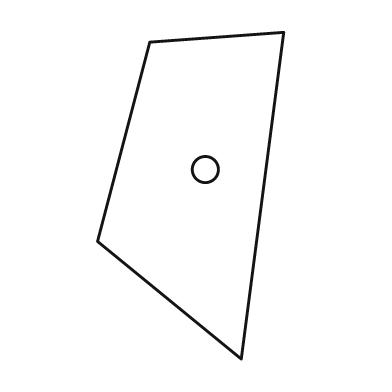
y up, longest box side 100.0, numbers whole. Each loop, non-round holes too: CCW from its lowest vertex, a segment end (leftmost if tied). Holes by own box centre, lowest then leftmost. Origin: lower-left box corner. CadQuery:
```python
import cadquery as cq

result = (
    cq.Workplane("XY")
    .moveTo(44.0, 0.0)
    .lineTo(57.0, 100.0)
    .lineTo(16.0, 97.0)
    .lineTo(0.0, 36.0)
    .close()
    .moveTo(33.0, 58.0)
    .circle(4.0)
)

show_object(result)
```